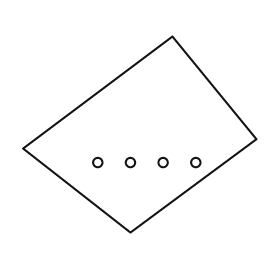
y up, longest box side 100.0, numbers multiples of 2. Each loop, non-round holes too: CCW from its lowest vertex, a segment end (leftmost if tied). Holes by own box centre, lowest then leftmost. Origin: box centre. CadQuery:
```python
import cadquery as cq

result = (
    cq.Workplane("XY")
    .moveTo(-4.0, -42.0)
    .lineTo(50.0, -2.0)
    .lineTo(14.0, 42.0)
    .lineTo(-50.0, -6.0)
    .close()
    .moveTo(-18.0, -12.0)
    .circle(2.0)
    .moveTo(-4.0, -12.0)
    .circle(2.0)
    .moveTo(10.0, -12.0)
    .circle(2.0)
    .moveTo(24.0, -12.0)
    .circle(2.0)
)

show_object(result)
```